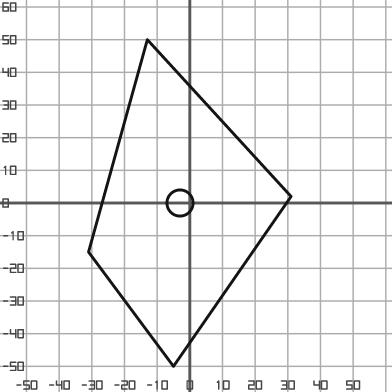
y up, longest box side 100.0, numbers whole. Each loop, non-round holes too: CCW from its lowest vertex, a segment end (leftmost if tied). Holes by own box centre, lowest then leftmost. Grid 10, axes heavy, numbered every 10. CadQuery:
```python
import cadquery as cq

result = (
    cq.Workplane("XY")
    .moveTo(-5.0, -50.0)
    .lineTo(31.0, 2.0)
    .lineTo(-13.0, 50.0)
    .lineTo(-31.0, -15.0)
    .close()
    .moveTo(-3.0, 0.0)
    .circle(4.0)
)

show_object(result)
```